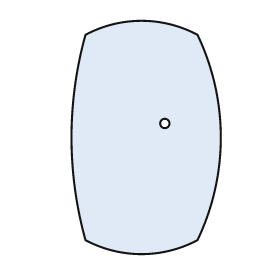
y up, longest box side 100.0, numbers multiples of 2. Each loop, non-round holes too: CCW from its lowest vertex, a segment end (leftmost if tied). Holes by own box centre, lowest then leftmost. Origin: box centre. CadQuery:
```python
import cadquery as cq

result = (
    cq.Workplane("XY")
    .moveTo(-26.0, -44.0)
    .threePointArc((-2.0, -50.0), (22.0, -44.0))
    .threePointArc((32.0, 0.0), (22.0, 44.0))
    .threePointArc((-2.0, 50.0), (-26.0, 44.0))
    .threePointArc((-32.0, 0.0), (-26.0, -44.0))
    .close()
    .moveTo(8.0, 6.0)
    .circle(2.0)
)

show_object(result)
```